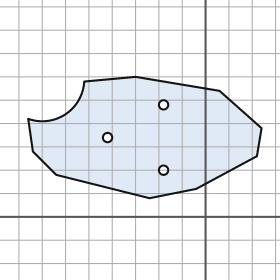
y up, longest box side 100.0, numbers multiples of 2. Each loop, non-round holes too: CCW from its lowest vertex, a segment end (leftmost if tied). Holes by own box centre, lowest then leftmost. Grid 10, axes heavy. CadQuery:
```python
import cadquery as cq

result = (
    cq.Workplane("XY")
    .moveTo(-24.0, 8.0)
    .lineTo(-4.0, 12.0)
    .lineTo(22.0, 26.0)
    .lineTo(24.0, 38.0)
    .lineTo(6.0, 54.0)
    .lineTo(-30.0, 60.0)
    .lineTo(-52.0, 58.0)
    .threePointArc((-60.0, 44.0), (-76.0, 42.0))
    .lineTo(-74.0, 28.0)
    .lineTo(-64.0, 18.0)
    .close()
    .moveTo(-18.0, 20.0)
    .circle(2.0)
    .moveTo(-42.0, 34.0)
    .circle(2.0)
    .moveTo(-18.0, 48.0)
    .circle(2.0)
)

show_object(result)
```